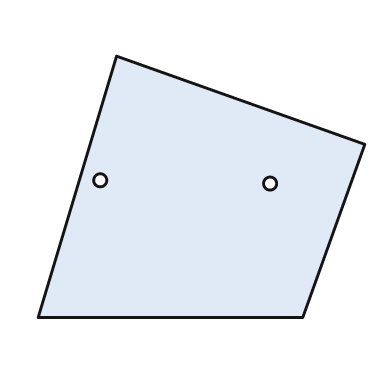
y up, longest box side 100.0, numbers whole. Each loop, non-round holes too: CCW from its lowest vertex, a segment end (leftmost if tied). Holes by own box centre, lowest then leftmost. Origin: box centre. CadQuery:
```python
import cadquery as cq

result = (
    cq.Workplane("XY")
    .moveTo(-50.0, -40.0)
    .lineTo(31.0, -40.0)
    .lineTo(50.0, 13.0)
    .lineTo(-26.0, 40.0)
    .close()
    .moveTo(21.0, 1.0)
    .circle(2.0)
    .moveTo(-31.0, 2.0)
    .circle(2.0)
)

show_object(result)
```